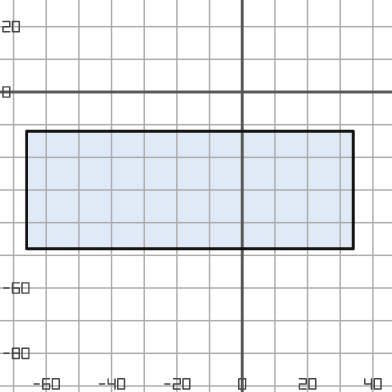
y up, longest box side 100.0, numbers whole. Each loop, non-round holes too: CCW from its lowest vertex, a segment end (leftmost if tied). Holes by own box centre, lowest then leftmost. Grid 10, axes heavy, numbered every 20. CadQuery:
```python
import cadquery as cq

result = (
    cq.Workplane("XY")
    .moveTo(-66.0, -48.0)
    .lineTo(34.0, -48.0)
    .lineTo(34.0, -12.0)
    .lineTo(-66.0, -12.0)
    .close()
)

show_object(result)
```